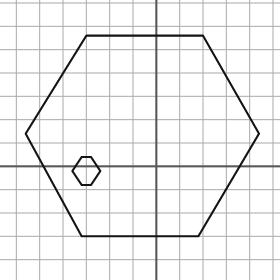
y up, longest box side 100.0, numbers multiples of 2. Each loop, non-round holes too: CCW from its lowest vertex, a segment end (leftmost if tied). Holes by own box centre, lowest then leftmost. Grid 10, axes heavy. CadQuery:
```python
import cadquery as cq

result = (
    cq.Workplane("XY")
    .moveTo(-32.0, -30.0)
    .lineTo(18.0, -30.0)
    .lineTo(44.0, 14.0)
    .lineTo(20.0, 56.0)
    .lineTo(-30.0, 56.0)
    .lineTo(-56.0, 14.0)
    .close()
    .moveTo(-32.0, -8.0)
    .lineTo(-28.0, -8.0)
    .lineTo(-24.0, -2.0)
    .lineTo(-28.0, 4.0)
    .lineTo(-32.0, 4.0)
    .lineTo(-36.0, -2.0)
    .close()
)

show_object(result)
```